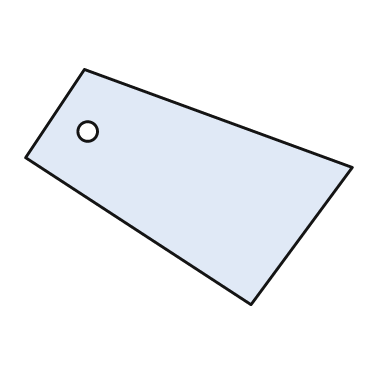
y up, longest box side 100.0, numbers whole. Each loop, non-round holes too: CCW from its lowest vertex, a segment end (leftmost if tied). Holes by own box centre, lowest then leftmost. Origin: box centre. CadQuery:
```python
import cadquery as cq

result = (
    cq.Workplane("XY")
    .moveTo(19.0, -36.0)
    .lineTo(50.0, 6.0)
    .lineTo(-32.0, 36.0)
    .lineTo(-50.0, 9.0)
    .close()
    .moveTo(-31.0, 17.0)
    .circle(3.0)
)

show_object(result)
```